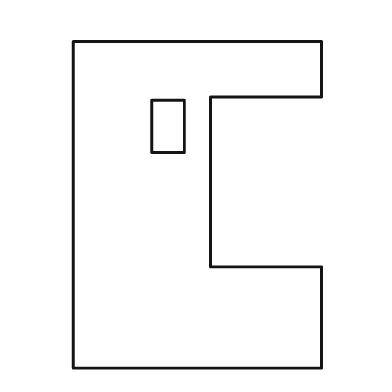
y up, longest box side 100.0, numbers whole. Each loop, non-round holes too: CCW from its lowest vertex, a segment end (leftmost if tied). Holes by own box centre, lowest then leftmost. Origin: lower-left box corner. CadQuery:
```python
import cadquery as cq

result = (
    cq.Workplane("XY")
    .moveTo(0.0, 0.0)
    .lineTo(76.0, 0.0)
    .lineTo(76.0, 31.0)
    .lineTo(42.0, 31.0)
    .lineTo(42.0, 83.0)
    .lineTo(76.0, 83.0)
    .lineTo(76.0, 100.0)
    .lineTo(0.0, 100.0)
    .close()
    .moveTo(24.0, 66.0)
    .lineTo(34.0, 66.0)
    .lineTo(34.0, 82.0)
    .lineTo(24.0, 82.0)
    .close()
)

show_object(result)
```